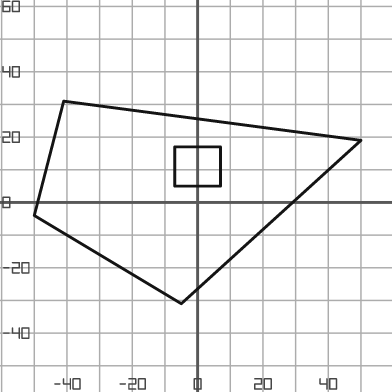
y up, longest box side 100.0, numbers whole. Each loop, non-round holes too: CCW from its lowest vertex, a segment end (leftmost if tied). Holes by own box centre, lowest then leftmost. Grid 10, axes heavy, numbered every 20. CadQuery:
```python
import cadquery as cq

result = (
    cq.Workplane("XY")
    .moveTo(-5.0, -31.0)
    .lineTo(50.0, 19.0)
    .lineTo(-41.0, 31.0)
    .lineTo(-50.0, -4.0)
    .close()
    .moveTo(-7.0, 5.0)
    .lineTo(7.0, 5.0)
    .lineTo(7.0, 17.0)
    .lineTo(-7.0, 17.0)
    .close()
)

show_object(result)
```